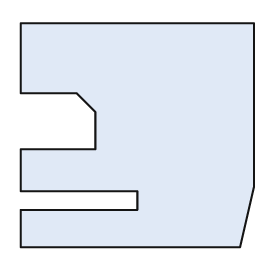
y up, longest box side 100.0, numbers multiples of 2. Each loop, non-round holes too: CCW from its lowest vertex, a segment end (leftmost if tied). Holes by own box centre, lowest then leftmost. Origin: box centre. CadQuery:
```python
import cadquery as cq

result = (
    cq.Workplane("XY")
    .moveTo(-50.0, -48.0)
    .lineTo(44.0, -48.0)
    .lineTo(50.0, -22.0)
    .lineTo(50.0, 48.0)
    .lineTo(-50.0, 48.0)
    .lineTo(-50.0, 18.0)
    .lineTo(-26.0, 18.0)
    .lineTo(-18.0, 10.0)
    .lineTo(-18.0, -6.0)
    .lineTo(-50.0, -6.0)
    .lineTo(-50.0, -24.0)
    .lineTo(0.0, -24.0)
    .lineTo(0.0, -32.0)
    .lineTo(-50.0, -32.0)
    .close()
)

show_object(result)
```